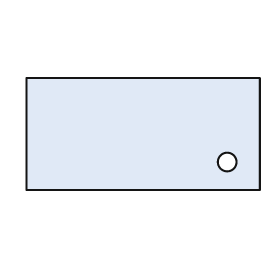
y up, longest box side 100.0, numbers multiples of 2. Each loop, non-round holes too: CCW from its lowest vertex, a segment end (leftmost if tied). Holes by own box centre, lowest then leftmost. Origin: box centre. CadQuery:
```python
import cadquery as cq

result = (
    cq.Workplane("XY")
    .moveTo(-50.0, -24.0)
    .lineTo(50.0, -24.0)
    .lineTo(50.0, 24.0)
    .lineTo(-50.0, 24.0)
    .close()
    .moveTo(36.0, -12.0)
    .circle(4.0)
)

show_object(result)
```